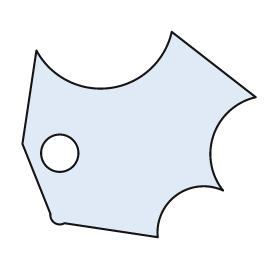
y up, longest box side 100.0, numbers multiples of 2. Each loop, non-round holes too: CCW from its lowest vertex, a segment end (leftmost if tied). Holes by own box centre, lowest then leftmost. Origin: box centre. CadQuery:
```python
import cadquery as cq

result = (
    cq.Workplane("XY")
    .moveTo(8.0, -44.0)
    .threePointArc((16.0, -26.0), (36.0, -24.0))
    .threePointArc((32.0, 0.0), (50.0, 16.0))
    .lineTo(14.0, 44.0)
    .threePointArc((-12.0, 20.0), (-44.0, 36.0))
    .lineTo(-50.0, -4.0)
    .lineTo(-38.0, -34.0)
    .threePointArc((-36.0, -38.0), (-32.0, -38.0))
    .close()
    .moveTo(-34.0, -8.0)
    .circle(8.0)
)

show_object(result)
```